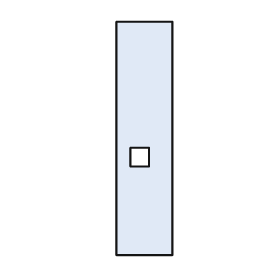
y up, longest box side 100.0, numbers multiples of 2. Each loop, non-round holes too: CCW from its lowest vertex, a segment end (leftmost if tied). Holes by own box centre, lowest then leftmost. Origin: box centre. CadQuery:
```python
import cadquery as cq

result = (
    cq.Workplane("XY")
    .moveTo(-12.0, -50.0)
    .lineTo(12.0, -50.0)
    .lineTo(12.0, 50.0)
    .lineTo(-12.0, 50.0)
    .close()
    .moveTo(-6.0, -12.0)
    .lineTo(2.0, -12.0)
    .lineTo(2.0, -4.0)
    .lineTo(-6.0, -4.0)
    .close()
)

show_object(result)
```